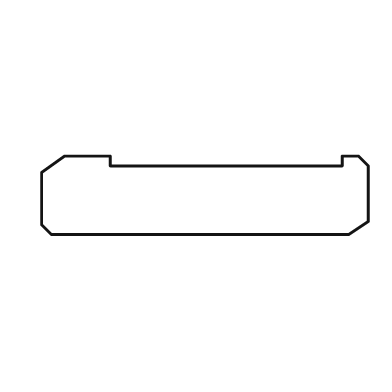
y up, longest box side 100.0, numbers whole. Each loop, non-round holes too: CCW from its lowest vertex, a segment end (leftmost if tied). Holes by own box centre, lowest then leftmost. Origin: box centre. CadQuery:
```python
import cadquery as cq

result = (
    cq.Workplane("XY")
    .moveTo(-47.0, -12.0)
    .lineTo(44.0, -12.0)
    .lineTo(50.0, -8.0)
    .lineTo(50.0, 9.0)
    .lineTo(47.0, 12.0)
    .lineTo(42.0, 12.0)
    .lineTo(42.0, 9.0)
    .lineTo(-29.0, 9.0)
    .lineTo(-29.0, 12.0)
    .lineTo(-43.0, 12.0)
    .lineTo(-50.0, 7.0)
    .lineTo(-50.0, -9.0)
    .close()
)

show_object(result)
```